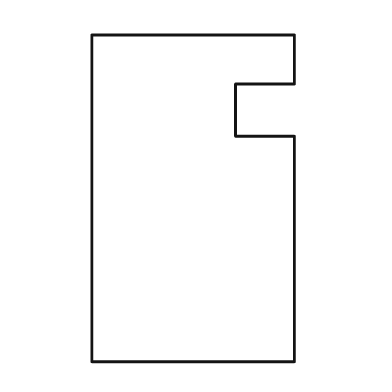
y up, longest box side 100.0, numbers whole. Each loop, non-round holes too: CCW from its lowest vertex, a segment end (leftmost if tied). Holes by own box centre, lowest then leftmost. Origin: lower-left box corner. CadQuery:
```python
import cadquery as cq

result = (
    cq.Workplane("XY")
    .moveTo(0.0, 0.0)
    .lineTo(62.0, 0.0)
    .lineTo(62.0, 69.0)
    .lineTo(44.0, 69.0)
    .lineTo(44.0, 85.0)
    .lineTo(62.0, 85.0)
    .lineTo(62.0, 100.0)
    .lineTo(0.0, 100.0)
    .close()
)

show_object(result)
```